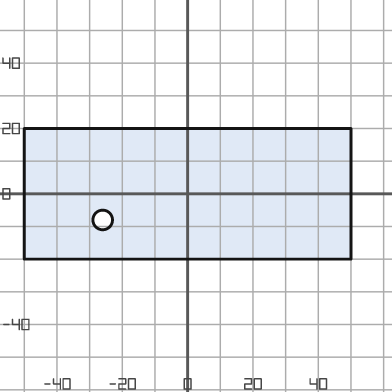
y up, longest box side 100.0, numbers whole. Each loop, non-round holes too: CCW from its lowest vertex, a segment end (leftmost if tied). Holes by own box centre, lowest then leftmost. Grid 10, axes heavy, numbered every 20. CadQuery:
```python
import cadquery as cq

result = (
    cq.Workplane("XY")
    .moveTo(-50.0, -20.0)
    .lineTo(50.0, -20.0)
    .lineTo(50.0, 20.0)
    .lineTo(-50.0, 20.0)
    .close()
    .moveTo(-26.0, -8.0)
    .circle(3.0)
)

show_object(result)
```